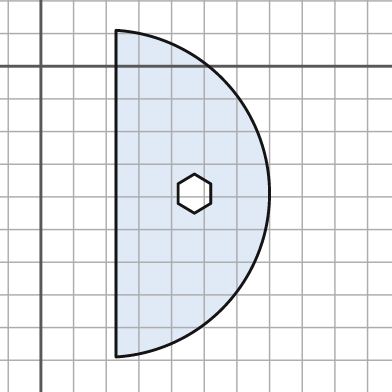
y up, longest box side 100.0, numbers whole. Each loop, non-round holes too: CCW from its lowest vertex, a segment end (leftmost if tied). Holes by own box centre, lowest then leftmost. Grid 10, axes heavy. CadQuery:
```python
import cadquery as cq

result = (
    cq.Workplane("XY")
    .moveTo(23.0, -89.0)
    .threePointArc((70.0, -39.0), (23.0, 11.0))
    .close()
    .moveTo(47.0, -45.0)
    .lineTo(52.0, -42.0)
    .lineTo(52.0, -36.0)
    .lineTo(47.0, -33.0)
    .lineTo(42.0, -36.0)
    .lineTo(42.0, -42.0)
    .close()
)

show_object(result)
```